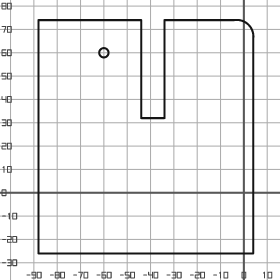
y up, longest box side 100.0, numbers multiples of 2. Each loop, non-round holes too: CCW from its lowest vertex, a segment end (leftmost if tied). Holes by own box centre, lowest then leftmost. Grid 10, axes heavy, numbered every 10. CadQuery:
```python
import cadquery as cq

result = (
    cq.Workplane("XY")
    .moveTo(-88.0, -26.0)
    .lineTo(4.0, -26.0)
    .lineTo(4.0, 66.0)
    .threePointArc((2.0, 72.0), (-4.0, 74.0))
    .lineTo(-34.0, 74.0)
    .lineTo(-34.0, 32.0)
    .lineTo(-44.0, 32.0)
    .lineTo(-44.0, 74.0)
    .lineTo(-88.0, 74.0)
    .close()
    .moveTo(-60.0, 60.0)
    .circle(2.0)
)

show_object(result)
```